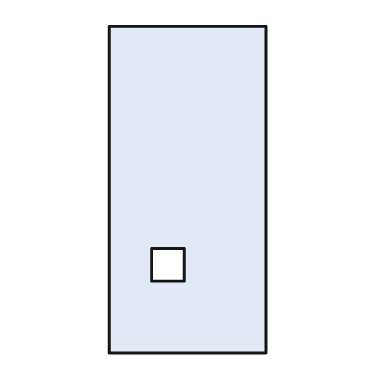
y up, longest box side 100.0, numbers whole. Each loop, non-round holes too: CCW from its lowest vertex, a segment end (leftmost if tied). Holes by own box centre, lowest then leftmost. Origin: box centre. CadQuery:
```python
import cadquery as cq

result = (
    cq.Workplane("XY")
    .moveTo(-24.0, -50.0)
    .lineTo(24.0, -50.0)
    .lineTo(24.0, 50.0)
    .lineTo(-24.0, 50.0)
    .close()
    .moveTo(-11.0, -28.0)
    .lineTo(-1.0, -28.0)
    .lineTo(-1.0, -18.0)
    .lineTo(-11.0, -18.0)
    .close()
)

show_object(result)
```